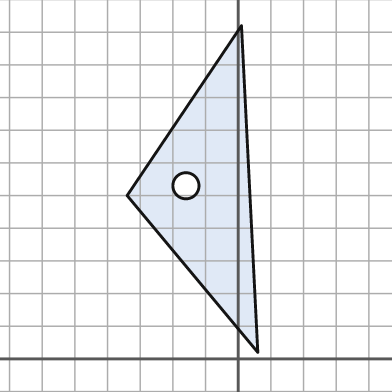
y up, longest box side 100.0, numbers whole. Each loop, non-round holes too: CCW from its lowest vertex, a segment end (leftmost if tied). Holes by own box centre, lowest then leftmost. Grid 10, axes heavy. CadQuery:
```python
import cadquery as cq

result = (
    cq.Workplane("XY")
    .moveTo(6.0, 2.0)
    .lineTo(1.0, 102.0)
    .lineTo(-34.0, 50.0)
    .close()
    .moveTo(-16.0, 53.0)
    .circle(4.0)
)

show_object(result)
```